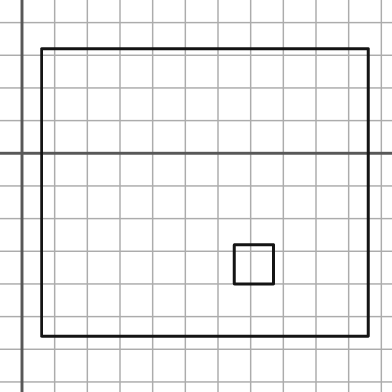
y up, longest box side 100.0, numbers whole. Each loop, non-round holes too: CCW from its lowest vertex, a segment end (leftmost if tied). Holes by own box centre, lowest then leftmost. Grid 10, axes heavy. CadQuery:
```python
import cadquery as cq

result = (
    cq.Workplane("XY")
    .moveTo(6.0, -56.0)
    .lineTo(106.0, -56.0)
    .lineTo(106.0, 32.0)
    .lineTo(6.0, 32.0)
    .close()
    .moveTo(65.0, -40.0)
    .lineTo(77.0, -40.0)
    .lineTo(77.0, -28.0)
    .lineTo(65.0, -28.0)
    .close()
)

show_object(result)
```